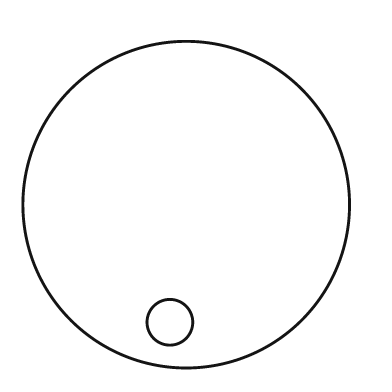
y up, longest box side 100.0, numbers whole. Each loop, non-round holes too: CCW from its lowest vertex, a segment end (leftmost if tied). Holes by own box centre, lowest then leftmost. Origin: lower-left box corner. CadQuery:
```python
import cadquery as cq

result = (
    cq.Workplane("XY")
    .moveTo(50.0, 50.0)
    .circle(50.0)
    .moveTo(45.0, 14.0)
    .circle(7.0)
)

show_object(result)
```